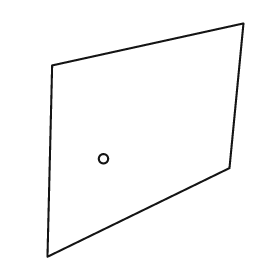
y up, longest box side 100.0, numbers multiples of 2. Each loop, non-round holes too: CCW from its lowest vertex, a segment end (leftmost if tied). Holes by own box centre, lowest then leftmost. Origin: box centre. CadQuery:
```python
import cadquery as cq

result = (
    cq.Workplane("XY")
    .moveTo(-42.0, -50.0)
    .lineTo(36.0, -12.0)
    .lineTo(42.0, 50.0)
    .lineTo(-40.0, 32.0)
    .close()
    .moveTo(-18.0, -8.0)
    .circle(2.0)
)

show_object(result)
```